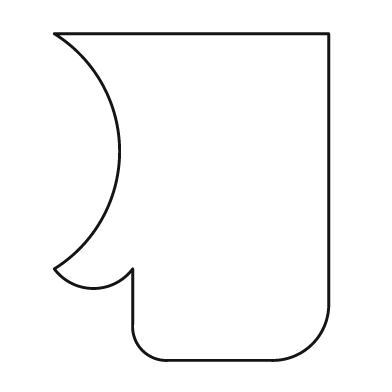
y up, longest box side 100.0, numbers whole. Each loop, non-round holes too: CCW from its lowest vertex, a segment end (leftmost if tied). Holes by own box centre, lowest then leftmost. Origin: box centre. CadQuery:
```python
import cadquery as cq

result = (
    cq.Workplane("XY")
    .moveTo(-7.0, -50.0)
    .lineTo(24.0, -50.0)
    .threePointArc((37.0, -45.0), (42.0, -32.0))
    .lineTo(42.0, 50.0)
    .lineTo(-42.0, 50.0)
    .threePointArc((-22.0, 14.0), (-42.0, -22.0))
    .threePointArc((-30.0, -28.0), (-18.0, -22.0))
    .lineTo(-18.0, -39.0)
    .threePointArc((-15.0, -47.0), (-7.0, -50.0))
    .close()
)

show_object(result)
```